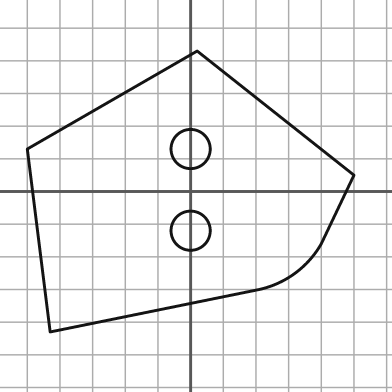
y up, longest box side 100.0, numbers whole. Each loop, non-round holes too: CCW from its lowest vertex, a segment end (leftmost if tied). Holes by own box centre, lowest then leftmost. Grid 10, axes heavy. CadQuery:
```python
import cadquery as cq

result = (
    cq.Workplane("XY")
    .moveTo(-43.0, -43.0)
    .lineTo(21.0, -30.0)
    .threePointArc((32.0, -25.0), (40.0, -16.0))
    .lineTo(50.0, 5.0)
    .lineTo(2.0, 43.0)
    .lineTo(-50.0, 13.0)
    .close()
    .moveTo(0.0, -12.0)
    .circle(6.0)
    .moveTo(0.0, 13.0)
    .circle(6.0)
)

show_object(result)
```